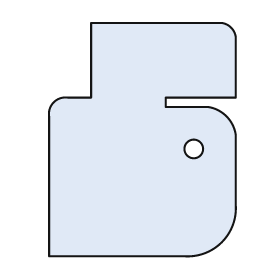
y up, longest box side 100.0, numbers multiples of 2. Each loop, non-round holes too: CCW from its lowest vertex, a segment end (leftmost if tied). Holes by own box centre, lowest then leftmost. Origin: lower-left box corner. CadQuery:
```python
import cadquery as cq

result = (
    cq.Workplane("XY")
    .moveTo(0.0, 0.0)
    .lineTo(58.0, 0.0)
    .threePointArc((74.0, 6.0), (80.0, 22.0))
    .lineTo(80.0, 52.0)
    .threePointArc((76.0, 60.0), (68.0, 64.0))
    .lineTo(50.0, 64.0)
    .lineTo(50.0, 68.0)
    .lineTo(80.0, 68.0)
    .lineTo(80.0, 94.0)
    .threePointArc((78.0, 98.0), (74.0, 100.0))
    .lineTo(18.0, 100.0)
    .lineTo(18.0, 68.0)
    .lineTo(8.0, 68.0)
    .threePointArc((2.0, 66.0), (0.0, 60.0))
    .close()
    .moveTo(62.0, 46.0)
    .circle(4.0)
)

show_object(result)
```